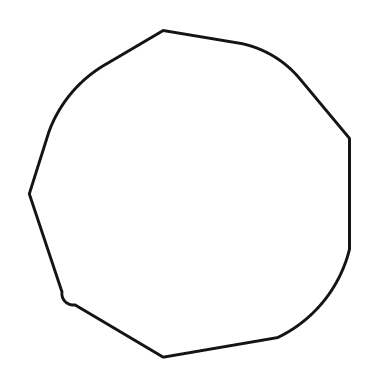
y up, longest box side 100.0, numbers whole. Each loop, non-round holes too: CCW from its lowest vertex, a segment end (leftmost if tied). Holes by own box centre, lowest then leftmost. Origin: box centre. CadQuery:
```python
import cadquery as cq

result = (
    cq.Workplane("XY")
    .moveTo(-8.0, -50.0)
    .lineTo(27.0, -44.0)
    .threePointArc((41.0, -33.0), (49.0, -17.0))
    .lineTo(49.0, 17.0)
    .lineTo(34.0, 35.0)
    .threePointArc((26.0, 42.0), (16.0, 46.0))
    .lineTo(-8.0, 50.0)
    .lineTo(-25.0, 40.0)
    .threePointArc((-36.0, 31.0), (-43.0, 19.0))
    .lineTo(-49.0, 0.0)
    .lineTo(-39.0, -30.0)
    .threePointArc((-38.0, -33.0), (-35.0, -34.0))
    .close()
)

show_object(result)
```